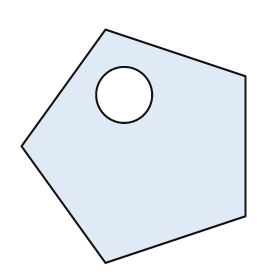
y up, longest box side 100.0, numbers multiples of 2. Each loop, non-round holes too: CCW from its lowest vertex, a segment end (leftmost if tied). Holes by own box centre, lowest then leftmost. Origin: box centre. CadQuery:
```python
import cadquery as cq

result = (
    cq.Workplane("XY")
    .moveTo(-12.0, -50.0)
    .lineTo(48.0, -30.0)
    .lineTo(48.0, 30.0)
    .lineTo(-12.0, 50.0)
    .lineTo(-48.0, 0.0)
    .close()
    .moveTo(-4.0, 22.0)
    .circle(12.0)
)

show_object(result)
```